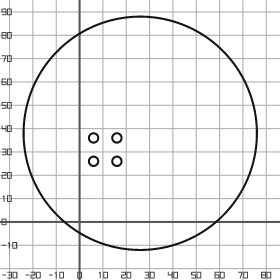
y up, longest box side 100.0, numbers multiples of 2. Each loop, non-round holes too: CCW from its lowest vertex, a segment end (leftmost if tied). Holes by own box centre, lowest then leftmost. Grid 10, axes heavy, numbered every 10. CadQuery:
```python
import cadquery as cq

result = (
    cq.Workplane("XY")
    .moveTo(26.0, 38.0)
    .circle(50.0)
    .moveTo(6.0, 26.0)
    .circle(2.0)
    .moveTo(16.0, 26.0)
    .circle(2.0)
    .moveTo(6.0, 36.0)
    .circle(2.0)
    .moveTo(16.0, 36.0)
    .circle(2.0)
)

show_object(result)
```